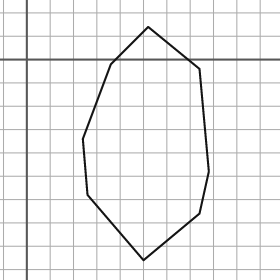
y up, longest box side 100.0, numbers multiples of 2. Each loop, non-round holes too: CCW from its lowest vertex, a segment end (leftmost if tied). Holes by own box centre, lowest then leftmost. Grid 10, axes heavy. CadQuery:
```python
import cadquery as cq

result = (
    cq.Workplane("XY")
    .moveTo(50.0, -86.0)
    .lineTo(74.0, -66.0)
    .lineTo(78.0, -48.0)
    .lineTo(74.0, -4.0)
    .lineTo(52.0, 14.0)
    .lineTo(36.0, -2.0)
    .lineTo(24.0, -34.0)
    .lineTo(26.0, -58.0)
    .close()
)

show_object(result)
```